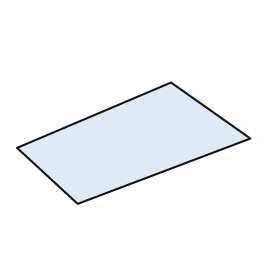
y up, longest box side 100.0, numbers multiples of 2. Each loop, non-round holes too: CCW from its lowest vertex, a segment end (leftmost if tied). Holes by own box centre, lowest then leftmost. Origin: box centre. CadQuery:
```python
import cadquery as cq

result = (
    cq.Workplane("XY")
    .moveTo(-24.0, -26.0)
    .lineTo(50.0, 2.0)
    .lineTo(16.0, 26.0)
    .lineTo(-50.0, -2.0)
    .close()
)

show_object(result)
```